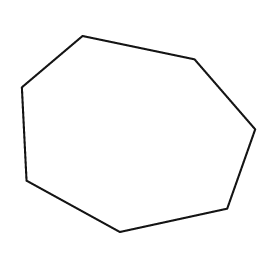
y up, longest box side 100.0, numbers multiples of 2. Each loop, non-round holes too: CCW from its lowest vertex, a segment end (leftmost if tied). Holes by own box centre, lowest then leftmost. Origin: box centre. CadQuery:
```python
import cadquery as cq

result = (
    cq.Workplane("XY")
    .moveTo(-8.0, -42.0)
    .lineTo(38.0, -32.0)
    .lineTo(50.0, 2.0)
    .lineTo(24.0, 32.0)
    .lineTo(-24.0, 42.0)
    .lineTo(-50.0, 20.0)
    .lineTo(-48.0, -20.0)
    .close()
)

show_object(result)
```